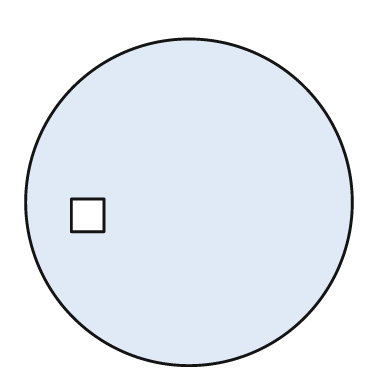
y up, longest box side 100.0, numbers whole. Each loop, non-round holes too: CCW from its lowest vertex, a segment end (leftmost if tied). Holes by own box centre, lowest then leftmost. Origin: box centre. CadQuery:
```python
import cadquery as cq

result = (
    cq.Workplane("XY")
    .moveTo(0.0, 0.0)
    .circle(50.0)
    .moveTo(-36.0, -9.0)
    .lineTo(-26.0, -9.0)
    .lineTo(-26.0, 1.0)
    .lineTo(-36.0, 1.0)
    .close()
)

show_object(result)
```